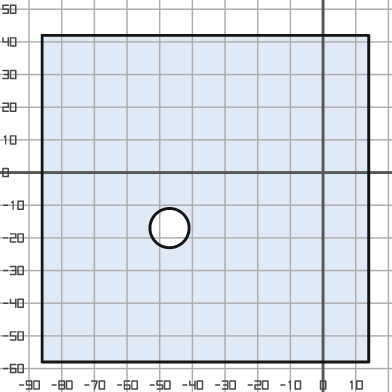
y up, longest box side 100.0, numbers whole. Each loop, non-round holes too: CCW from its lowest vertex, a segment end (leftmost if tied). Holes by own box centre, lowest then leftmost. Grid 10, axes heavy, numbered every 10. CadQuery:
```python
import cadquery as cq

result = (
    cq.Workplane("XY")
    .moveTo(-86.0, -58.0)
    .lineTo(14.0, -58.0)
    .lineTo(14.0, 42.0)
    .lineTo(-86.0, 42.0)
    .close()
    .moveTo(-47.0, -17.0)
    .circle(6.0)
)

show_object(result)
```